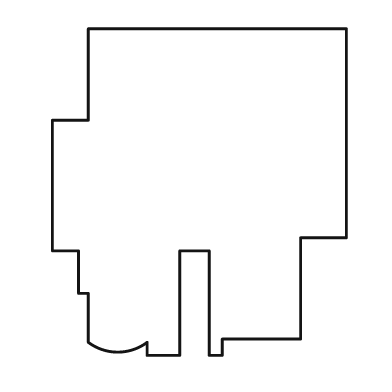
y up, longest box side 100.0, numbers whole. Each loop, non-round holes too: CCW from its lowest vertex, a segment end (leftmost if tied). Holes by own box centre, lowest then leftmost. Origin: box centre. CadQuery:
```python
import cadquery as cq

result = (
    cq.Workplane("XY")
    .moveTo(-16.0, -50.0)
    .lineTo(-6.0, -50.0)
    .lineTo(-6.0, -18.0)
    .lineTo(3.0, -18.0)
    .lineTo(3.0, -50.0)
    .lineTo(7.0, -50.0)
    .lineTo(7.0, -45.0)
    .lineTo(31.0, -45.0)
    .lineTo(31.0, -14.0)
    .lineTo(45.0, -14.0)
    .lineTo(45.0, 50.0)
    .lineTo(-34.0, 50.0)
    .lineTo(-34.0, 22.0)
    .lineTo(-45.0, 22.0)
    .lineTo(-45.0, -18.0)
    .lineTo(-37.0, -18.0)
    .lineTo(-37.0, -31.0)
    .lineTo(-34.0, -31.0)
    .lineTo(-34.0, -46.0)
    .threePointArc((-25.0, -49.0), (-16.0, -46.0))
    .close()
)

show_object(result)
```